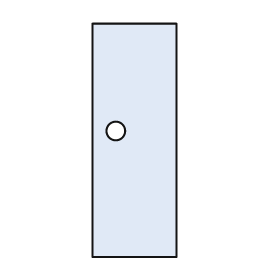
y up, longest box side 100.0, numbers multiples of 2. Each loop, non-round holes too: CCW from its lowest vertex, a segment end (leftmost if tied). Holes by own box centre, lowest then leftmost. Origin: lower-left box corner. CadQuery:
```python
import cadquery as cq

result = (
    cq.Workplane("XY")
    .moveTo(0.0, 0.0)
    .lineTo(36.0, 0.0)
    .lineTo(36.0, 100.0)
    .lineTo(0.0, 100.0)
    .close()
    .moveTo(10.0, 54.0)
    .circle(4.0)
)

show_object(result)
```